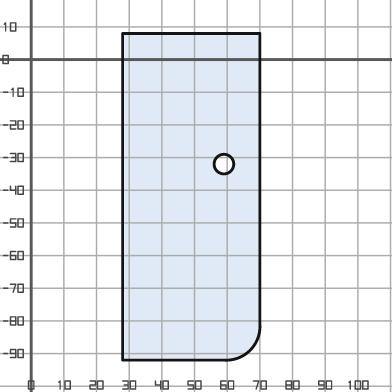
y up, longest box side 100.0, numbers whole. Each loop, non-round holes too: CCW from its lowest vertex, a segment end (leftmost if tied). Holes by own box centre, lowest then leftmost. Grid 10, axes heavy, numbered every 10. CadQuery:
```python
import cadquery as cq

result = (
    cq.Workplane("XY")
    .moveTo(28.0, -92.0)
    .lineTo(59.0, -92.0)
    .threePointArc((67.0, -89.0), (70.0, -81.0))
    .lineTo(70.0, 8.0)
    .lineTo(28.0, 8.0)
    .close()
    .moveTo(59.0, -32.0)
    .circle(3.0)
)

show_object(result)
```